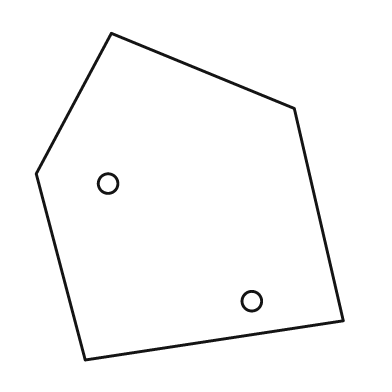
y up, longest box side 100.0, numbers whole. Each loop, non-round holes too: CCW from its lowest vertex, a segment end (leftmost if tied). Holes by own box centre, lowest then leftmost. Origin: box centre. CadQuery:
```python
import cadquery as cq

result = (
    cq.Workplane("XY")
    .moveTo(-32.0, -50.0)
    .lineTo(47.0, -38.0)
    .lineTo(32.0, 27.0)
    .lineTo(-24.0, 50.0)
    .lineTo(-47.0, 7.0)
    .close()
    .moveTo(19.0, -32.0)
    .circle(3.0)
    .moveTo(-25.0, 4.0)
    .circle(3.0)
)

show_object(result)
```